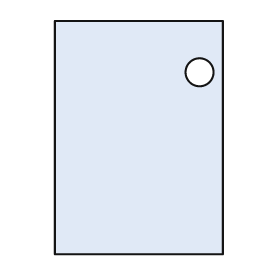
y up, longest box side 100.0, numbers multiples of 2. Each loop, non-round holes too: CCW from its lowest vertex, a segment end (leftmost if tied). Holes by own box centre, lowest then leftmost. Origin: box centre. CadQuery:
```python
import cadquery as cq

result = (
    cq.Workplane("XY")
    .moveTo(-36.0, -50.0)
    .lineTo(36.0, -50.0)
    .lineTo(36.0, 50.0)
    .lineTo(-36.0, 50.0)
    .close()
    .moveTo(26.0, 28.0)
    .circle(6.0)
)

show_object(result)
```